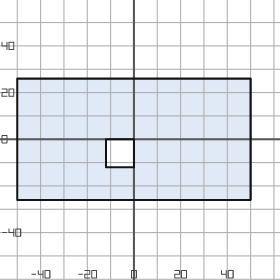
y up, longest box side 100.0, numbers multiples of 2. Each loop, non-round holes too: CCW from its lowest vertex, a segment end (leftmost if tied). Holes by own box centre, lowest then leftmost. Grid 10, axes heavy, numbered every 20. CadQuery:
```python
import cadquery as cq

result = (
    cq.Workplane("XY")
    .moveTo(-50.0, -26.0)
    .lineTo(50.0, -26.0)
    .lineTo(50.0, 26.0)
    .lineTo(-50.0, 26.0)
    .close()
    .moveTo(-12.0, -12.0)
    .lineTo(0.0, -12.0)
    .lineTo(0.0, 0.0)
    .lineTo(-12.0, 0.0)
    .close()
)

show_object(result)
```